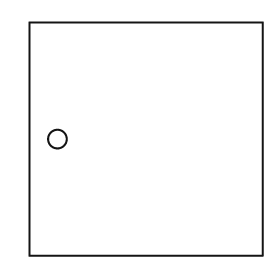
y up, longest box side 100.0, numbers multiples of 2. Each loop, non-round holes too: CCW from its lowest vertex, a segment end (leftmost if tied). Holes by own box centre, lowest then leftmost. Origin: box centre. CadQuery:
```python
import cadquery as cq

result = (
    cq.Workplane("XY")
    .moveTo(-50.0, -50.0)
    .lineTo(50.0, -50.0)
    .lineTo(50.0, 50.0)
    .lineTo(-50.0, 50.0)
    .close()
    .moveTo(-38.0, 0.0)
    .circle(4.0)
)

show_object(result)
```